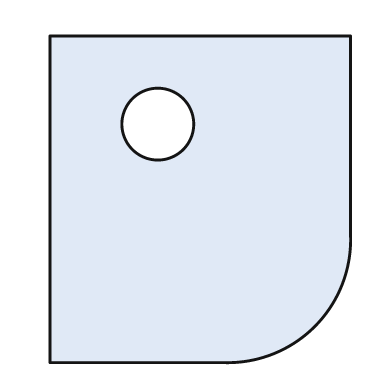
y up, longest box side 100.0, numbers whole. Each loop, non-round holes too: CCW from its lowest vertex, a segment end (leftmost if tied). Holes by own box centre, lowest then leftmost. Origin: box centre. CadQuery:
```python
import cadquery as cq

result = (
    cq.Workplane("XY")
    .moveTo(-46.0, -50.0)
    .lineTo(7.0, -50.0)
    .threePointArc((35.0, -39.0), (46.0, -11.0))
    .lineTo(46.0, 50.0)
    .lineTo(-46.0, 50.0)
    .close()
    .moveTo(-13.0, 23.0)
    .circle(11.0)
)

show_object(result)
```